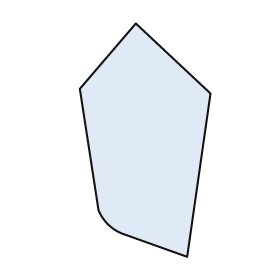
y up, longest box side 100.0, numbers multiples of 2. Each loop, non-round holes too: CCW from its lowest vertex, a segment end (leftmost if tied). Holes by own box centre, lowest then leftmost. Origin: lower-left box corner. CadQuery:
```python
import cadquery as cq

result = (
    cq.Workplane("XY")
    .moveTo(46.0, 0.0)
    .lineTo(56.0, 70.0)
    .lineTo(24.0, 100.0)
    .lineTo(0.0, 72.0)
    .lineTo(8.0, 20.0)
    .threePointArc((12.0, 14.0), (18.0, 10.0))
    .close()
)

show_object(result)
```